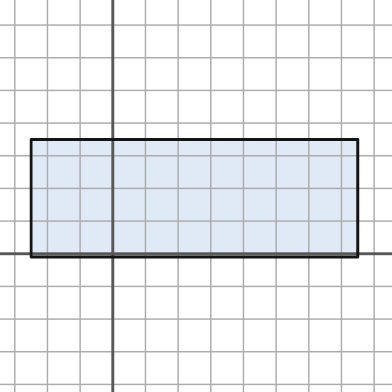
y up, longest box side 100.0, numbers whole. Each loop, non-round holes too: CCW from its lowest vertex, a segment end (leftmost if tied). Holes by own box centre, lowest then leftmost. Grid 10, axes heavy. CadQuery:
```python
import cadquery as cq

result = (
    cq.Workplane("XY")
    .moveTo(-25.0, -1.0)
    .lineTo(75.0, -1.0)
    .lineTo(75.0, 35.0)
    .lineTo(-25.0, 35.0)
    .close()
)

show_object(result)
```